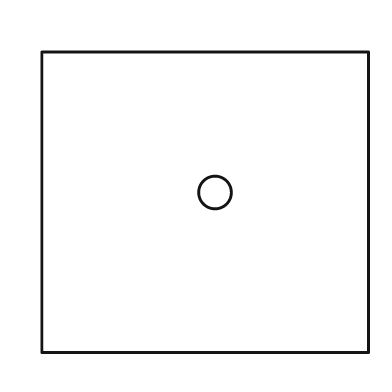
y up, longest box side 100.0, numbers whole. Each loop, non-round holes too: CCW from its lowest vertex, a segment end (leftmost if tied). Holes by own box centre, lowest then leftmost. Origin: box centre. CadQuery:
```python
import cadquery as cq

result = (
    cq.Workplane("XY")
    .moveTo(-50.0, -46.0)
    .lineTo(50.0, -46.0)
    .lineTo(50.0, 46.0)
    .lineTo(-50.0, 46.0)
    .close()
    .moveTo(3.0, 3.0)
    .circle(5.0)
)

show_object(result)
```